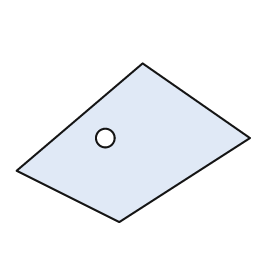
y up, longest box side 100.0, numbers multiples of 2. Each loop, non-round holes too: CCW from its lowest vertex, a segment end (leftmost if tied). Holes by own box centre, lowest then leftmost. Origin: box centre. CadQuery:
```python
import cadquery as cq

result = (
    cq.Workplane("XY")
    .moveTo(-6.0, -34.0)
    .lineTo(50.0, 2.0)
    .lineTo(4.0, 34.0)
    .lineTo(-50.0, -12.0)
    .close()
    .moveTo(-12.0, 2.0)
    .circle(4.0)
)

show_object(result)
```